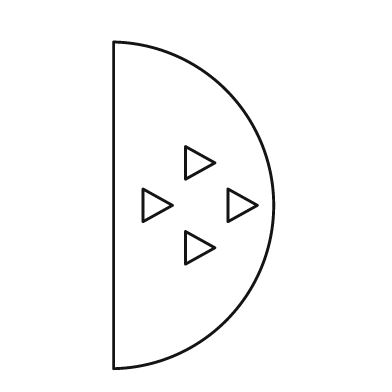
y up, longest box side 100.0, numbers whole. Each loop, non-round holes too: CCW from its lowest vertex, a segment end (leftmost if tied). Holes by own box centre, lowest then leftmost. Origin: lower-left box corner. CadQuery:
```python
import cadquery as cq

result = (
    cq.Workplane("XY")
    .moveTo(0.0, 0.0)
    .threePointArc((49.0, 50.0), (0.0, 100.0))
    .close()
    .moveTo(22.0, 32.0)
    .lineTo(31.0, 37.0)
    .lineTo(22.0, 42.0)
    .close()
    .moveTo(9.0, 45.0)
    .lineTo(18.0, 50.0)
    .lineTo(9.0, 55.0)
    .close()
    .moveTo(35.0, 45.0)
    .lineTo(44.0, 50.0)
    .lineTo(35.0, 55.0)
    .close()
    .moveTo(22.0, 58.0)
    .lineTo(31.0, 63.0)
    .lineTo(22.0, 68.0)
    .close()
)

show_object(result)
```